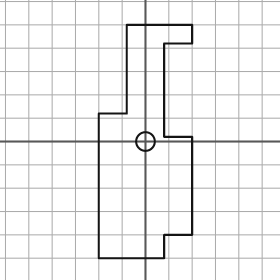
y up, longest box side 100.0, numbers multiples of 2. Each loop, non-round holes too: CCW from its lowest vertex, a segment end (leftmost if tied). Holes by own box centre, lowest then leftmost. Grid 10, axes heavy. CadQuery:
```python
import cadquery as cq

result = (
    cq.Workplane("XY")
    .moveTo(-20.0, -50.0)
    .lineTo(8.0, -50.0)
    .lineTo(8.0, -40.0)
    .lineTo(20.0, -40.0)
    .lineTo(20.0, 2.0)
    .lineTo(8.0, 2.0)
    .lineTo(8.0, 42.0)
    .lineTo(20.0, 42.0)
    .lineTo(20.0, 50.0)
    .lineTo(-8.0, 50.0)
    .lineTo(-8.0, 12.0)
    .lineTo(-20.0, 12.0)
    .close()
    .moveTo(0.0, 0.0)
    .circle(4.0)
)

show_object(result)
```